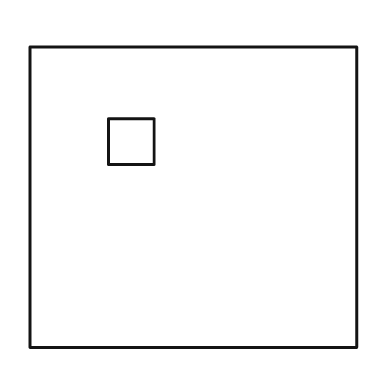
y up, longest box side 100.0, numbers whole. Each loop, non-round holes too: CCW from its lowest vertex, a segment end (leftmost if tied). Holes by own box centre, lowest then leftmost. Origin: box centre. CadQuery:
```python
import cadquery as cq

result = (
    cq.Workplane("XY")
    .moveTo(-50.0, -46.0)
    .lineTo(50.0, -46.0)
    .lineTo(50.0, 46.0)
    .lineTo(-50.0, 46.0)
    .close()
    .moveTo(-26.0, 10.0)
    .lineTo(-12.0, 10.0)
    .lineTo(-12.0, 24.0)
    .lineTo(-26.0, 24.0)
    .close()
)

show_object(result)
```